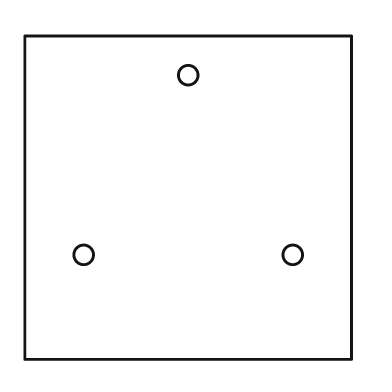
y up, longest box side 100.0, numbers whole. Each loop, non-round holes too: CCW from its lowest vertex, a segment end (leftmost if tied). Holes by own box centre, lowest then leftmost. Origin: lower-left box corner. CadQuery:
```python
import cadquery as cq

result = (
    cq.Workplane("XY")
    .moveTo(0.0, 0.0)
    .lineTo(100.0, 0.0)
    .lineTo(100.0, 99.0)
    .lineTo(0.0, 99.0)
    .close()
    .moveTo(18.0, 32.0)
    .circle(3.0)
    .moveTo(82.0, 32.0)
    .circle(3.0)
    .moveTo(50.0, 87.0)
    .circle(3.0)
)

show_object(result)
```